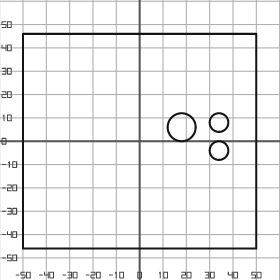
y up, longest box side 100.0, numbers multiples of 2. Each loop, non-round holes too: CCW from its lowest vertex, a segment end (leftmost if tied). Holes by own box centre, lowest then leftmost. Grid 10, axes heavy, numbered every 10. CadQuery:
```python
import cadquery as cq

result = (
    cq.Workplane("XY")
    .moveTo(-50.0, -46.0)
    .lineTo(50.0, -46.0)
    .lineTo(50.0, 46.0)
    .lineTo(-50.0, 46.0)
    .close()
    .moveTo(34.0, -4.0)
    .circle(4.0)
    .moveTo(18.0, 6.0)
    .circle(6.0)
    .moveTo(34.0, 8.0)
    .circle(4.0)
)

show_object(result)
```